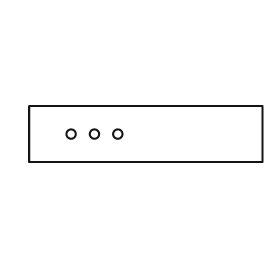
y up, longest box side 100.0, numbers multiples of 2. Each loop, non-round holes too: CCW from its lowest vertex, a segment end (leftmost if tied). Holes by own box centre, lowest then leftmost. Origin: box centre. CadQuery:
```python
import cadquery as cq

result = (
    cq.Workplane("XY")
    .moveTo(-50.0, -12.0)
    .lineTo(50.0, -12.0)
    .lineTo(50.0, 12.0)
    .lineTo(-50.0, 12.0)
    .close()
    .moveTo(-32.0, 0.0)
    .circle(2.0)
    .moveTo(-22.0, 0.0)
    .circle(2.0)
    .moveTo(-12.0, 0.0)
    .circle(2.0)
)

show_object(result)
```